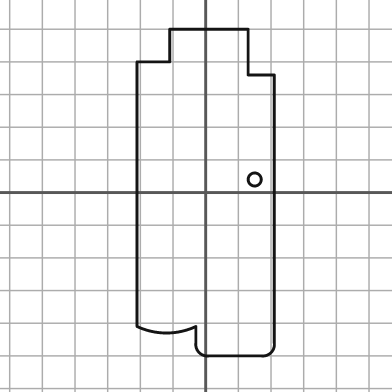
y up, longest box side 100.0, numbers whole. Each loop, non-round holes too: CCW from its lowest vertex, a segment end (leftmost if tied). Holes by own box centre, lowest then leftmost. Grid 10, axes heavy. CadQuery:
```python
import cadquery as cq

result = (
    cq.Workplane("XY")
    .moveTo(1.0, -50.0)
    .lineTo(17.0, -50.0)
    .threePointArc((20.0, -49.0), (21.0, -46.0))
    .lineTo(21.0, 36.0)
    .lineTo(13.0, 36.0)
    .lineTo(13.0, 50.0)
    .lineTo(-11.0, 50.0)
    .lineTo(-11.0, 40.0)
    .lineTo(-21.0, 40.0)
    .lineTo(-21.0, -41.0)
    .threePointArc((-12.0, -43.0), (-3.0, -41.0))
    .lineTo(-3.0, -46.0)
    .threePointArc((-2.0, -49.0), (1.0, -50.0))
    .close()
    .moveTo(15.0, 4.0)
    .circle(2.0)
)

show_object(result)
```